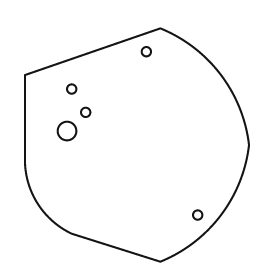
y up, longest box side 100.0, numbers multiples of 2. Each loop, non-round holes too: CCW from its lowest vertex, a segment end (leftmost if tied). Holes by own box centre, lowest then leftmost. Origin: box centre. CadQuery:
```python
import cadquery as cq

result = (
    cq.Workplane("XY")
    .moveTo(10.0, -50.0)
    .threePointArc((36.0, -30.0), (48.0, 0.0))
    .threePointArc((36.0, 30.0), (10.0, 50.0))
    .lineTo(-48.0, 30.0)
    .lineTo(-48.0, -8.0)
    .threePointArc((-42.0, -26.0), (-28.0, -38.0))
    .close()
    .moveTo(26.0, -30.0)
    .circle(2.0)
    .moveTo(-30.0, 6.0)
    .circle(4.0)
    .moveTo(-22.0, 14.0)
    .circle(2.0)
    .moveTo(-28.0, 24.0)
    .circle(2.0)
    .moveTo(4.0, 40.0)
    .circle(2.0)
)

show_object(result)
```